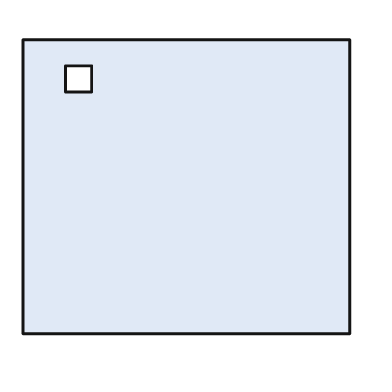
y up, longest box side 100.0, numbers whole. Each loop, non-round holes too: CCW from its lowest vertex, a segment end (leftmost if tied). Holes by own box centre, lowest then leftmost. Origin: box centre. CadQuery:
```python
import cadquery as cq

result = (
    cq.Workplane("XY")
    .moveTo(-50.0, -45.0)
    .lineTo(50.0, -45.0)
    .lineTo(50.0, 45.0)
    .lineTo(-50.0, 45.0)
    .close()
    .moveTo(-37.0, 29.0)
    .lineTo(-29.0, 29.0)
    .lineTo(-29.0, 37.0)
    .lineTo(-37.0, 37.0)
    .close()
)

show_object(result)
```